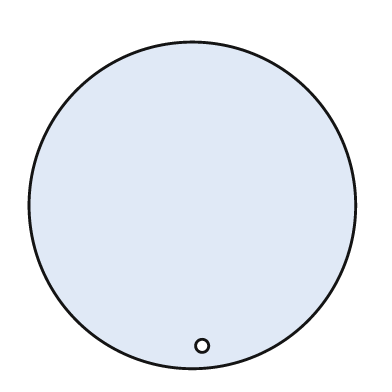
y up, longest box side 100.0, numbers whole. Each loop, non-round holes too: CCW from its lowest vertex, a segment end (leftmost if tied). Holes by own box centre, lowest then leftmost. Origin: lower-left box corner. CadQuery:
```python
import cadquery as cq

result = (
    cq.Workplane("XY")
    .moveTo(50.0, 50.0)
    .circle(50.0)
    .moveTo(53.0, 7.0)
    .circle(2.0)
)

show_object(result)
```